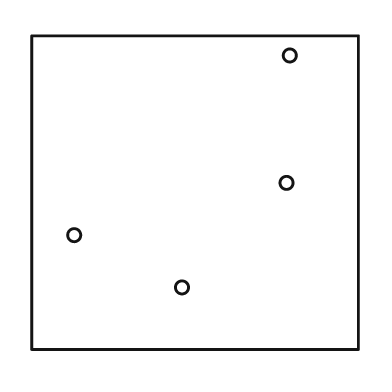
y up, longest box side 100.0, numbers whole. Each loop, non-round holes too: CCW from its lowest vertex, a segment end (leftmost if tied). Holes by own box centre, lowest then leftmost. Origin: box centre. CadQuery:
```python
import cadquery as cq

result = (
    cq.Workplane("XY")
    .moveTo(-50.0, -48.0)
    .lineTo(50.0, -48.0)
    .lineTo(50.0, 48.0)
    .lineTo(-50.0, 48.0)
    .close()
    .moveTo(-4.0, -29.0)
    .circle(2.0)
    .moveTo(-37.0, -13.0)
    .circle(2.0)
    .moveTo(28.0, 3.0)
    .circle(2.0)
    .moveTo(29.0, 42.0)
    .circle(2.0)
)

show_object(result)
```